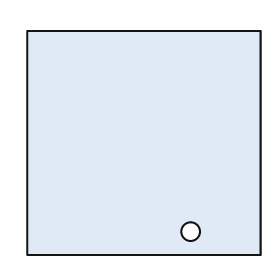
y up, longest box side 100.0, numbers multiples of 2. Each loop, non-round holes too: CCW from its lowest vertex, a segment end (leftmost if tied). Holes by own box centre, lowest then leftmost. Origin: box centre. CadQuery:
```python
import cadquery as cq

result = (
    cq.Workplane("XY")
    .moveTo(-50.0, -48.0)
    .lineTo(50.0, -48.0)
    .lineTo(50.0, 48.0)
    .lineTo(-50.0, 48.0)
    .close()
    .moveTo(20.0, -38.0)
    .circle(4.0)
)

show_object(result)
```